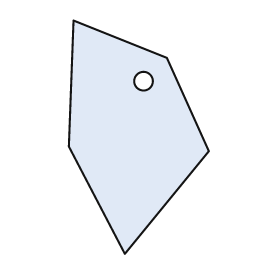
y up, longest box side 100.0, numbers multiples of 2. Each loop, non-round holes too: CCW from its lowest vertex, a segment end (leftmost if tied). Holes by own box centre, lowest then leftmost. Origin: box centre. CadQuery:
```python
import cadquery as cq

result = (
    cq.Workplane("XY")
    .moveTo(-6.0, -50.0)
    .lineTo(30.0, -6.0)
    .lineTo(12.0, 34.0)
    .lineTo(-28.0, 50.0)
    .lineTo(-30.0, -4.0)
    .close()
    .moveTo(2.0, 24.0)
    .circle(4.0)
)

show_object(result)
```